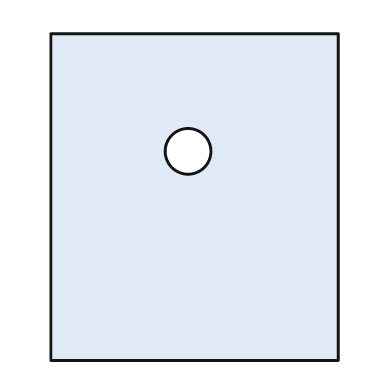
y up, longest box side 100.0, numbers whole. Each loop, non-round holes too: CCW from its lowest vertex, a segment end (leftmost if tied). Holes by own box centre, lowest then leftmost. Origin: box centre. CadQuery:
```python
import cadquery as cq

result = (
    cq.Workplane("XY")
    .moveTo(-44.0, -50.0)
    .lineTo(44.0, -50.0)
    .lineTo(44.0, 50.0)
    .lineTo(-44.0, 50.0)
    .close()
    .moveTo(-2.0, 14.0)
    .circle(7.0)
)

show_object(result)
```